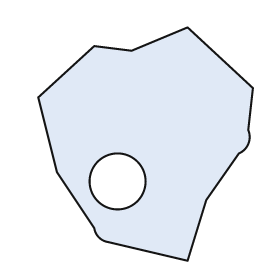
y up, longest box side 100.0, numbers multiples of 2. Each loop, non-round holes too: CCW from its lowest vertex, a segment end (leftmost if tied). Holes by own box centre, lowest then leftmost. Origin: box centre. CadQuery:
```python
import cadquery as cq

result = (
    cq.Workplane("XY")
    .moveTo(18.0, -50.0)
    .lineTo(26.0, -24.0)
    .lineTo(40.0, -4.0)
    .threePointArc((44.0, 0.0), (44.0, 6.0))
    .lineTo(46.0, 24.0)
    .lineTo(18.0, 50.0)
    .lineTo(-6.0, 40.0)
    .lineTo(-22.0, 42.0)
    .lineTo(-46.0, 20.0)
    .lineTo(-38.0, -12.0)
    .lineTo(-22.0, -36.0)
    .threePointArc((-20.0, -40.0), (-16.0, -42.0))
    .close()
    .moveTo(-12.0, -16.0)
    .circle(12.0)
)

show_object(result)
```